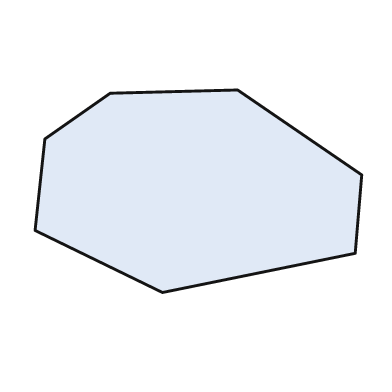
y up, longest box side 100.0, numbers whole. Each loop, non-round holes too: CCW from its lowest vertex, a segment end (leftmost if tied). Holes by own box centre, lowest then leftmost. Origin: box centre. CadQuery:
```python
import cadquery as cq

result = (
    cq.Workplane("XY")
    .moveTo(-11.0, -31.0)
    .lineTo(48.0, -19.0)
    .lineTo(50.0, 5.0)
    .lineTo(12.0, 31.0)
    .lineTo(-27.0, 30.0)
    .lineTo(-47.0, 16.0)
    .lineTo(-50.0, -12.0)
    .close()
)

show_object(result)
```